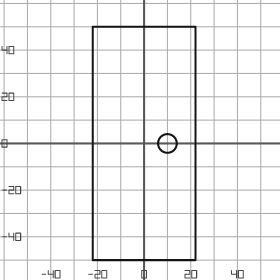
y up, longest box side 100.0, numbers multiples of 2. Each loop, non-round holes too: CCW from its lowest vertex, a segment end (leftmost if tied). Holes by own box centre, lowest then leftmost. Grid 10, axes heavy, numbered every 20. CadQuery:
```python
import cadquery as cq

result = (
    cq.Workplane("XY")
    .moveTo(-22.0, -50.0)
    .lineTo(22.0, -50.0)
    .lineTo(22.0, 50.0)
    .lineTo(-22.0, 50.0)
    .close()
    .moveTo(10.0, 0.0)
    .circle(4.0)
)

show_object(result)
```